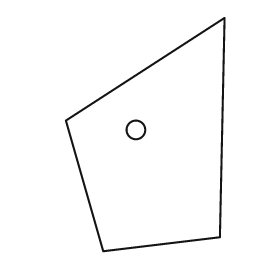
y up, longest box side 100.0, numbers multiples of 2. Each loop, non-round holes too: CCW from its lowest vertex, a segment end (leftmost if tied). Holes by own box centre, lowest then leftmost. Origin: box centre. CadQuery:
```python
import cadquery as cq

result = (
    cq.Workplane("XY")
    .moveTo(-18.0, -50.0)
    .lineTo(32.0, -44.0)
    .lineTo(34.0, 50.0)
    .lineTo(-34.0, 6.0)
    .close()
    .moveTo(-4.0, 2.0)
    .circle(4.0)
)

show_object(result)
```